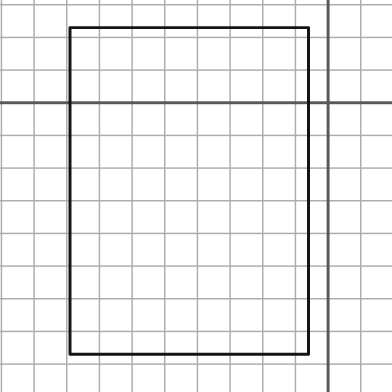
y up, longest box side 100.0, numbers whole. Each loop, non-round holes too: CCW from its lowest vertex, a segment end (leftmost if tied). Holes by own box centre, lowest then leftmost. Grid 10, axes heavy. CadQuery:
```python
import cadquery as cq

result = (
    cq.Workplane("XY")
    .moveTo(-79.0, -77.0)
    .lineTo(-6.0, -77.0)
    .lineTo(-6.0, 23.0)
    .lineTo(-79.0, 23.0)
    .close()
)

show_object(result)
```